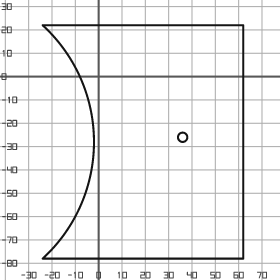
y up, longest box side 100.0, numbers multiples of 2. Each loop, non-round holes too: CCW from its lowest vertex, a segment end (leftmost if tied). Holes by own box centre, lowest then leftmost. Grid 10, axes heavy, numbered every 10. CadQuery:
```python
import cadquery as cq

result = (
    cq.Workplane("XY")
    .moveTo(-24.0, -78.0)
    .lineTo(62.0, -78.0)
    .lineTo(62.0, 22.0)
    .lineTo(-24.0, 22.0)
    .threePointArc((-2.0, -28.0), (-24.0, -78.0))
    .close()
    .moveTo(36.0, -26.0)
    .circle(2.0)
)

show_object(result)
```